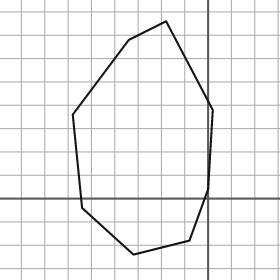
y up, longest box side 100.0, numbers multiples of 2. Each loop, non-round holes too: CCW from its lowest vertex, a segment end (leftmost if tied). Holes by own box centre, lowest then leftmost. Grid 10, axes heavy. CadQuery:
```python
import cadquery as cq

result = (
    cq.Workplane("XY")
    .moveTo(-32.0, -24.0)
    .lineTo(-8.0, -18.0)
    .lineTo(0.0, 4.0)
    .lineTo(2.0, 38.0)
    .lineTo(-18.0, 76.0)
    .lineTo(-34.0, 68.0)
    .lineTo(-58.0, 36.0)
    .lineTo(-54.0, -4.0)
    .close()
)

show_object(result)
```